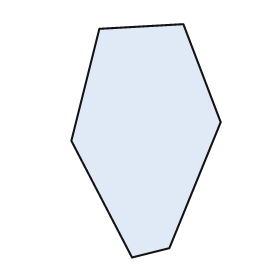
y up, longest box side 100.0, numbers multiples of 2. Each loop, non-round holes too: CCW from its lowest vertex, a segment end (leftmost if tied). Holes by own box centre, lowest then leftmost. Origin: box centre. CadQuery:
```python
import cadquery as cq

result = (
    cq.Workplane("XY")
    .moveTo(-6.0, -50.0)
    .lineTo(10.0, -46.0)
    .lineTo(32.0, 8.0)
    .lineTo(16.0, 50.0)
    .lineTo(-20.0, 48.0)
    .lineTo(-32.0, 0.0)
    .close()
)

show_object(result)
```